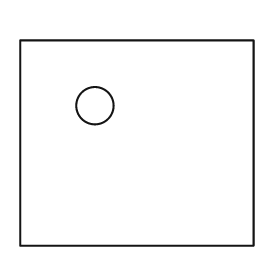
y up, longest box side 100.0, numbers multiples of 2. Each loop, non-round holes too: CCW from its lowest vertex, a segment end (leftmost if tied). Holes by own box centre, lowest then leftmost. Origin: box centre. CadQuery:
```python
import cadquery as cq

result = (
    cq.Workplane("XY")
    .moveTo(-50.0, -44.0)
    .lineTo(50.0, -44.0)
    .lineTo(50.0, 44.0)
    .lineTo(-50.0, 44.0)
    .close()
    .moveTo(-18.0, 16.0)
    .circle(8.0)
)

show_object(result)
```